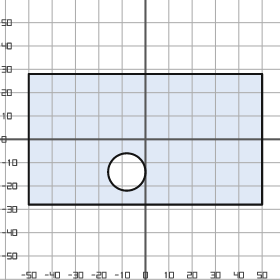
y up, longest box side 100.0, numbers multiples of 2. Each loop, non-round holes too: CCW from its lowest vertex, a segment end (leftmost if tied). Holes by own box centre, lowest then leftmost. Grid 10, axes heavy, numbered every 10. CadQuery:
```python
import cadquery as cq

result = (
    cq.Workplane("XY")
    .moveTo(-50.0, -28.0)
    .lineTo(50.0, -28.0)
    .lineTo(50.0, 28.0)
    .lineTo(-50.0, 28.0)
    .close()
    .moveTo(-8.0, -14.0)
    .circle(8.0)
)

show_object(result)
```